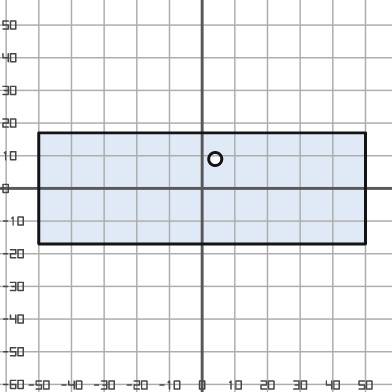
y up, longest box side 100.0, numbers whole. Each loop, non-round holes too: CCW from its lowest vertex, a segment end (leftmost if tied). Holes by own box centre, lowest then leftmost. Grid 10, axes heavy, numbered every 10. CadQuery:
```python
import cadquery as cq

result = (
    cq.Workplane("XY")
    .moveTo(-50.0, -17.0)
    .lineTo(50.0, -17.0)
    .lineTo(50.0, 17.0)
    .lineTo(-50.0, 17.0)
    .close()
    .moveTo(4.0, 9.0)
    .circle(2.0)
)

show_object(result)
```